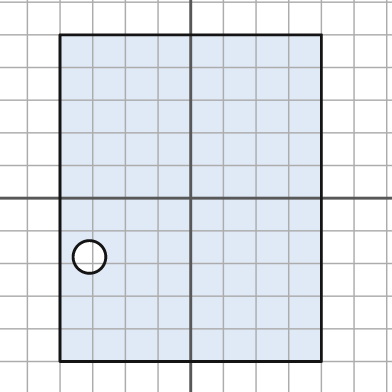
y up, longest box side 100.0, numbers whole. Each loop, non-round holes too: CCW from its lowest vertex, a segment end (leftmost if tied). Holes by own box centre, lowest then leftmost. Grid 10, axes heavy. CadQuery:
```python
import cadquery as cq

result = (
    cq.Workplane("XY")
    .moveTo(-40.0, -50.0)
    .lineTo(40.0, -50.0)
    .lineTo(40.0, 50.0)
    .lineTo(-40.0, 50.0)
    .close()
    .moveTo(-31.0, -18.0)
    .circle(5.0)
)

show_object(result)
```